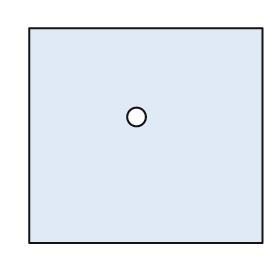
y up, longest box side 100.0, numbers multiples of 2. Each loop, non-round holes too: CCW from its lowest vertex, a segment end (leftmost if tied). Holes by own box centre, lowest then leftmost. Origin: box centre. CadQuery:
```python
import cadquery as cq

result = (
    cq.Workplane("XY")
    .moveTo(-50.0, -46.0)
    .lineTo(50.0, -46.0)
    .lineTo(50.0, 46.0)
    .lineTo(-50.0, 46.0)
    .close()
    .moveTo(-4.0, 8.0)
    .circle(4.0)
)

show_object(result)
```